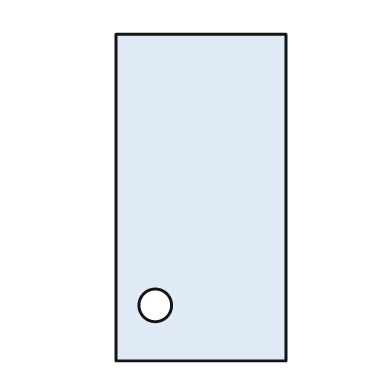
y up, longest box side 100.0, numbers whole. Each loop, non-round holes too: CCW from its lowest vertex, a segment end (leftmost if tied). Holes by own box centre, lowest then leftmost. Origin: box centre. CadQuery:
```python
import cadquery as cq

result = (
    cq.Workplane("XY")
    .moveTo(-26.0, -50.0)
    .lineTo(26.0, -50.0)
    .lineTo(26.0, 50.0)
    .lineTo(-26.0, 50.0)
    .close()
    .moveTo(-14.0, -33.0)
    .circle(5.0)
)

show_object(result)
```